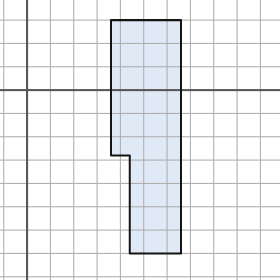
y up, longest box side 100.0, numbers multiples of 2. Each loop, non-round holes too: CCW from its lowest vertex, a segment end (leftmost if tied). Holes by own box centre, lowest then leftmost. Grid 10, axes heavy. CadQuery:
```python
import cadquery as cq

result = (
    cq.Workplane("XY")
    .moveTo(44.0, -70.0)
    .lineTo(66.0, -70.0)
    .lineTo(66.0, 30.0)
    .lineTo(36.0, 30.0)
    .lineTo(36.0, -28.0)
    .lineTo(44.0, -28.0)
    .close()
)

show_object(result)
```